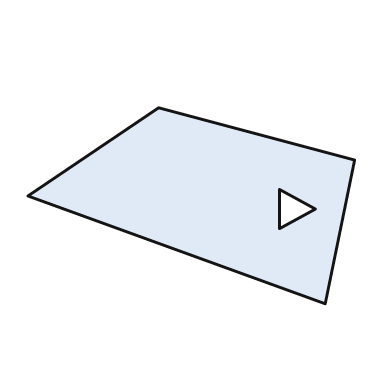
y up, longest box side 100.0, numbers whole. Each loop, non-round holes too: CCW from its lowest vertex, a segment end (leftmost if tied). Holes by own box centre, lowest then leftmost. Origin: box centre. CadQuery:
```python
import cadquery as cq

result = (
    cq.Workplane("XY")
    .moveTo(41.0, -30.0)
    .lineTo(50.0, 14.0)
    .lineTo(-10.0, 30.0)
    .lineTo(-50.0, 3.0)
    .close()
    .moveTo(27.0, -7.0)
    .lineTo(38.0, -1.0)
    .lineTo(27.0, 5.0)
    .close()
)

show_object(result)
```